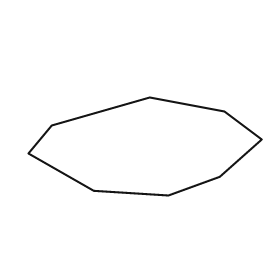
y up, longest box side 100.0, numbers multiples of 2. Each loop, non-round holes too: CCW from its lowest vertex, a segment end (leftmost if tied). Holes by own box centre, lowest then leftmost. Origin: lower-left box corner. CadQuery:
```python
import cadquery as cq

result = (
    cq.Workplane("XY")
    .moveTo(60.0, 0.0)
    .lineTo(82.0, 8.0)
    .lineTo(100.0, 24.0)
    .lineTo(84.0, 36.0)
    .lineTo(52.0, 42.0)
    .lineTo(10.0, 30.0)
    .lineTo(0.0, 18.0)
    .lineTo(28.0, 2.0)
    .close()
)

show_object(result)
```